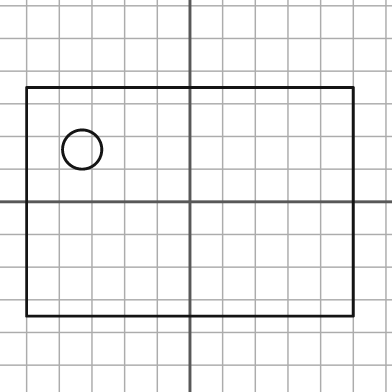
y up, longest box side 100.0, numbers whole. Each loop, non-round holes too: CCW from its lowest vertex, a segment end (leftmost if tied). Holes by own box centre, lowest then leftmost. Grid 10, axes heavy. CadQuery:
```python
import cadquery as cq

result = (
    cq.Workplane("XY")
    .moveTo(-50.0, -35.0)
    .lineTo(50.0, -35.0)
    .lineTo(50.0, 35.0)
    .lineTo(-50.0, 35.0)
    .close()
    .moveTo(-33.0, 16.0)
    .circle(6.0)
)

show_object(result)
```